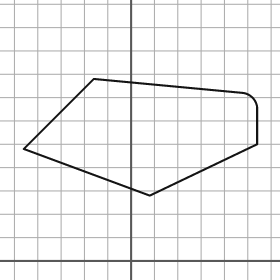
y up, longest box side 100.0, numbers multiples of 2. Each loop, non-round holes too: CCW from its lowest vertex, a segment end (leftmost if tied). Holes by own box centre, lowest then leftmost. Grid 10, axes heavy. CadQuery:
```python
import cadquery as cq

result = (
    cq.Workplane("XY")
    .moveTo(8.0, 28.0)
    .lineTo(54.0, 50.0)
    .lineTo(54.0, 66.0)
    .threePointArc((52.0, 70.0), (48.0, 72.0))
    .lineTo(-16.0, 78.0)
    .lineTo(-46.0, 48.0)
    .close()
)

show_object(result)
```